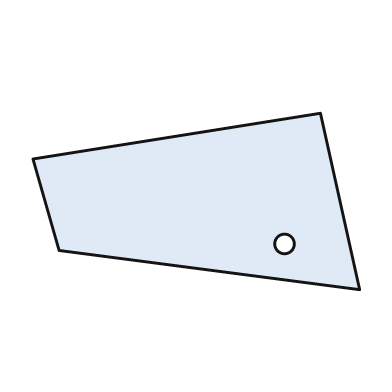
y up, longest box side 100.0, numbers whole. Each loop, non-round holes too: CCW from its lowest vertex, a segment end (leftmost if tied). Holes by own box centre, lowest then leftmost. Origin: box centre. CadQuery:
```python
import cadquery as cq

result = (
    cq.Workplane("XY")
    .moveTo(50.0, -27.0)
    .lineTo(38.0, 27.0)
    .lineTo(-50.0, 13.0)
    .lineTo(-42.0, -15.0)
    .close()
    .moveTo(27.0, -13.0)
    .circle(3.0)
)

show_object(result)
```